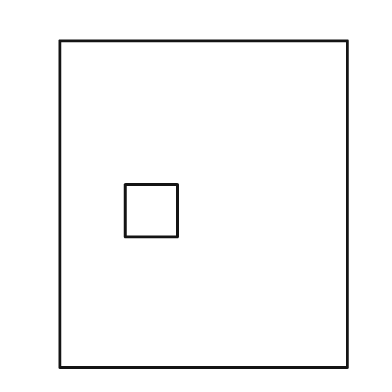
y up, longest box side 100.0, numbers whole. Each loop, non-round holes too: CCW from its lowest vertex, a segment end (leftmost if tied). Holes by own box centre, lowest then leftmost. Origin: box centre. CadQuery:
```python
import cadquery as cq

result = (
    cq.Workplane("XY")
    .moveTo(-44.0, -50.0)
    .lineTo(44.0, -50.0)
    .lineTo(44.0, 50.0)
    .lineTo(-44.0, 50.0)
    .close()
    .moveTo(-24.0, -10.0)
    .lineTo(-8.0, -10.0)
    .lineTo(-8.0, 6.0)
    .lineTo(-24.0, 6.0)
    .close()
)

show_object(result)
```